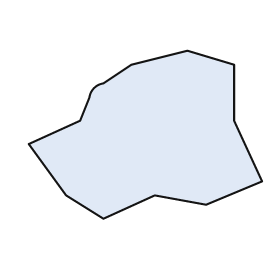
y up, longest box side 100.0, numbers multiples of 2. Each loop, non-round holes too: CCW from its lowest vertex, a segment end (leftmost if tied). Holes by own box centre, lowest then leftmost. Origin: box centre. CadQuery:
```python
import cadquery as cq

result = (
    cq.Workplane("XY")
    .moveTo(-18.0, -36.0)
    .lineTo(4.0, -26.0)
    .lineTo(26.0, -30.0)
    .lineTo(50.0, -20.0)
    .lineTo(38.0, 6.0)
    .lineTo(38.0, 30.0)
    .lineTo(18.0, 36.0)
    .lineTo(-6.0, 30.0)
    .lineTo(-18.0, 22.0)
    .threePointArc((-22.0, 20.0), (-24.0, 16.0))
    .lineTo(-28.0, 6.0)
    .lineTo(-50.0, -4.0)
    .lineTo(-34.0, -26.0)
    .close()
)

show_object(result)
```